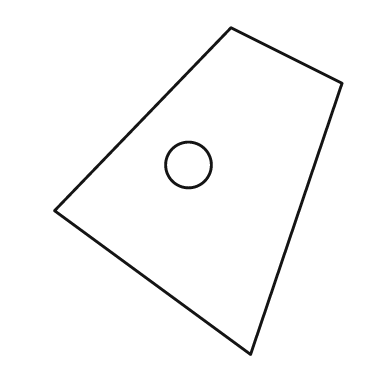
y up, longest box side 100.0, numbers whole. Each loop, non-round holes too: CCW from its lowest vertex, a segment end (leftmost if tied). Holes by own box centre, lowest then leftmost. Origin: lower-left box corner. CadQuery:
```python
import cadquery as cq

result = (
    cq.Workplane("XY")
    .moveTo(60.0, 0.0)
    .lineTo(88.0, 83.0)
    .lineTo(54.0, 100.0)
    .lineTo(0.0, 44.0)
    .close()
    .moveTo(41.0, 58.0)
    .circle(7.0)
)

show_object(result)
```